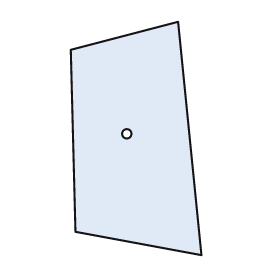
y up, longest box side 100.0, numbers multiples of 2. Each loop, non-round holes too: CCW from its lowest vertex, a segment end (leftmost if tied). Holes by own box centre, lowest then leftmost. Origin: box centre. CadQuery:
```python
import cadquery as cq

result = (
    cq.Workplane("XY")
    .moveTo(28.0, -50.0)
    .lineTo(18.0, 50.0)
    .lineTo(-28.0, 38.0)
    .lineTo(-26.0, -40.0)
    .close()
    .moveTo(-4.0, 2.0)
    .circle(2.0)
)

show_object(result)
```